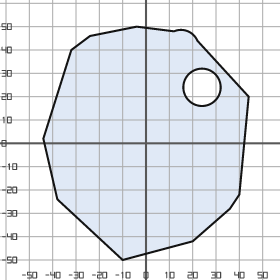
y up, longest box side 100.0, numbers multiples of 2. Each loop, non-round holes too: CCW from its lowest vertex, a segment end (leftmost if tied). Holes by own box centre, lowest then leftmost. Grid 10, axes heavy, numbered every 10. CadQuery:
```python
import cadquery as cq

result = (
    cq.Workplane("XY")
    .moveTo(-10.0, -50.0)
    .lineTo(20.0, -42.0)
    .lineTo(36.0, -28.0)
    .lineTo(40.0, -22.0)
    .lineTo(44.0, 20.0)
    .lineTo(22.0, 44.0)
    .threePointArc((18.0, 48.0), (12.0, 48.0))
    .lineTo(-4.0, 50.0)
    .lineTo(-24.0, 46.0)
    .lineTo(-32.0, 40.0)
    .lineTo(-44.0, 2.0)
    .lineTo(-38.0, -24.0)
    .close()
    .moveTo(24.0, 24.0)
    .circle(8.0)
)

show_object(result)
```